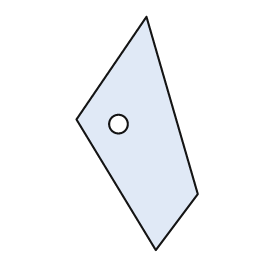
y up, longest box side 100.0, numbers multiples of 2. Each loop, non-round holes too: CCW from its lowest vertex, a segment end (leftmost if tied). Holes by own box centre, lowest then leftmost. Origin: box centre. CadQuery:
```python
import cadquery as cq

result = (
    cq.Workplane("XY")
    .moveTo(8.0, -50.0)
    .lineTo(26.0, -26.0)
    .lineTo(4.0, 50.0)
    .lineTo(-26.0, 6.0)
    .close()
    .moveTo(-8.0, 4.0)
    .circle(4.0)
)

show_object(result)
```